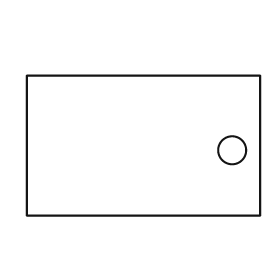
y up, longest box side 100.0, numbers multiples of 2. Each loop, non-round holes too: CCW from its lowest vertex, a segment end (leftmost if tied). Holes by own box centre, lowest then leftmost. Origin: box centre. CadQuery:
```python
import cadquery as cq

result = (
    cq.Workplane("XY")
    .moveTo(-50.0, -30.0)
    .lineTo(50.0, -30.0)
    .lineTo(50.0, 30.0)
    .lineTo(-50.0, 30.0)
    .close()
    .moveTo(38.0, -2.0)
    .circle(6.0)
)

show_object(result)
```